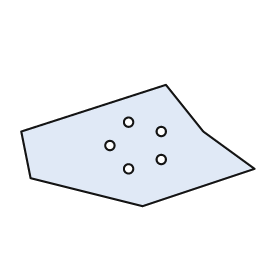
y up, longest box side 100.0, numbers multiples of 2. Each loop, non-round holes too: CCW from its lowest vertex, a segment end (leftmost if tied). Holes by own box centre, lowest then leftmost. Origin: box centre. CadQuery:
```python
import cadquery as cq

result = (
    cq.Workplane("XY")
    .moveTo(2.0, -26.0)
    .lineTo(50.0, -10.0)
    .lineTo(28.0, 6.0)
    .lineTo(12.0, 26.0)
    .lineTo(-50.0, 6.0)
    .lineTo(-46.0, -14.0)
    .close()
    .moveTo(-4.0, -10.0)
    .circle(2.0)
    .moveTo(10.0, -6.0)
    .circle(2.0)
    .moveTo(-12.0, 0.0)
    .circle(2.0)
    .moveTo(10.0, 6.0)
    .circle(2.0)
    .moveTo(-4.0, 10.0)
    .circle(2.0)
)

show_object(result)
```